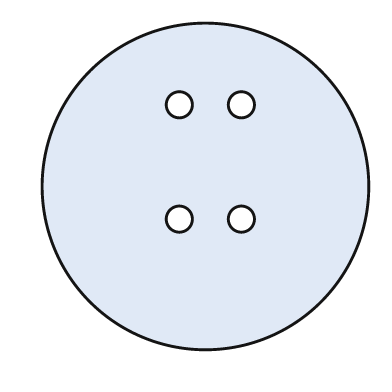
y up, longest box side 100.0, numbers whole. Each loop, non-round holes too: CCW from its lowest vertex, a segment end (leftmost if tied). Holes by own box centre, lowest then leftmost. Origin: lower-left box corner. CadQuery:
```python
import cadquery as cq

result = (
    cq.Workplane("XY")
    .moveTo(50.0, 50.0)
    .circle(50.0)
    .moveTo(42.0, 40.0)
    .circle(4.0)
    .moveTo(61.0, 40.0)
    .circle(4.0)
    .moveTo(42.0, 75.0)
    .circle(4.0)
    .moveTo(61.0, 75.0)
    .circle(4.0)
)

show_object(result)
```